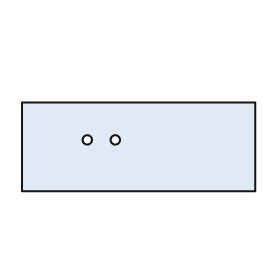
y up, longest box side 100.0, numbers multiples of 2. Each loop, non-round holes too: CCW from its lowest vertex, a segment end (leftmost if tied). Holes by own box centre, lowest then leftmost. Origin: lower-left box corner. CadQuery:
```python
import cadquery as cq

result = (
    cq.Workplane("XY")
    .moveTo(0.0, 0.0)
    .lineTo(100.0, 0.0)
    .lineTo(100.0, 38.0)
    .lineTo(0.0, 38.0)
    .close()
    .moveTo(28.0, 22.0)
    .circle(2.0)
    .moveTo(40.0, 22.0)
    .circle(2.0)
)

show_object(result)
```